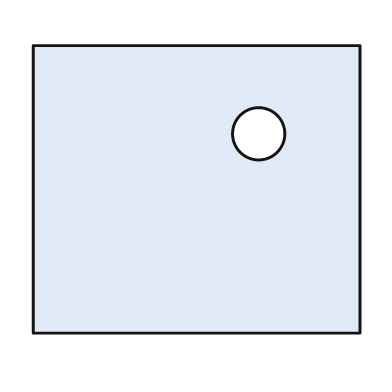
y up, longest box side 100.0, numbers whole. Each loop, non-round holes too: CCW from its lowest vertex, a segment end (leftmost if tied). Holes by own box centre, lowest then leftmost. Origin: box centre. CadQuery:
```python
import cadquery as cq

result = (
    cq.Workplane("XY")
    .moveTo(-50.0, -44.0)
    .lineTo(50.0, -44.0)
    .lineTo(50.0, 44.0)
    .lineTo(-50.0, 44.0)
    .close()
    .moveTo(19.0, 17.0)
    .circle(8.0)
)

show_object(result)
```